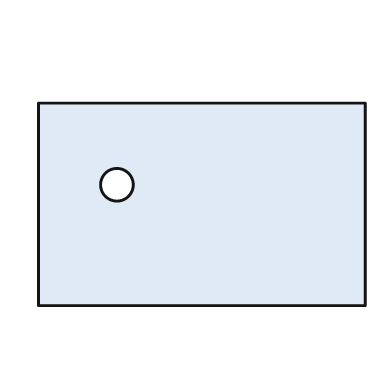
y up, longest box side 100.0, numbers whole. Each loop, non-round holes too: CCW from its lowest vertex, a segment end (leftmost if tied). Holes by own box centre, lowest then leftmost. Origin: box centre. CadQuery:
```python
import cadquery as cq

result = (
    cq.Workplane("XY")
    .moveTo(-50.0, -31.0)
    .lineTo(50.0, -31.0)
    .lineTo(50.0, 31.0)
    .lineTo(-50.0, 31.0)
    .close()
    .moveTo(-26.0, 6.0)
    .circle(5.0)
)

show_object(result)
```